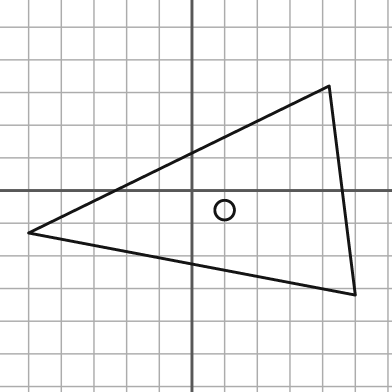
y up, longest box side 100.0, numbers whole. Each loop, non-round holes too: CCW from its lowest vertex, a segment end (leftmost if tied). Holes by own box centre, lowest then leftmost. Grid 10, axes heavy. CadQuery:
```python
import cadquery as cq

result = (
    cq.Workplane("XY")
    .moveTo(50.0, -32.0)
    .lineTo(42.0, 32.0)
    .lineTo(-50.0, -13.0)
    .close()
    .moveTo(10.0, -6.0)
    .circle(3.0)
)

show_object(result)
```